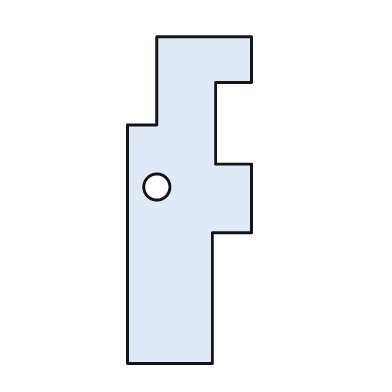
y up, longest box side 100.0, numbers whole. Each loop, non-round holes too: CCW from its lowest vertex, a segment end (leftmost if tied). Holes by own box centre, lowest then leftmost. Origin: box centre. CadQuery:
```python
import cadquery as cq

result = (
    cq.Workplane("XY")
    .moveTo(-19.0, -50.0)
    .lineTo(7.0, -50.0)
    .lineTo(7.0, -10.0)
    .lineTo(19.0, -10.0)
    .lineTo(19.0, 11.0)
    .lineTo(8.0, 11.0)
    .lineTo(8.0, 36.0)
    .lineTo(19.0, 36.0)
    .lineTo(19.0, 50.0)
    .lineTo(-10.0, 50.0)
    .lineTo(-10.0, 23.0)
    .lineTo(-19.0, 23.0)
    .close()
    .moveTo(-10.0, 4.0)
    .circle(4.0)
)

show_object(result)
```